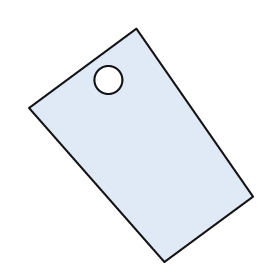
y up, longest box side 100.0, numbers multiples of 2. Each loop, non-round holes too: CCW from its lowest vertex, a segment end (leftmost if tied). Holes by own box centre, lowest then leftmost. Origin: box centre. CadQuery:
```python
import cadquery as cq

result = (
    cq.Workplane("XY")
    .moveTo(10.0, -50.0)
    .lineTo(48.0, -22.0)
    .lineTo(-2.0, 50.0)
    .lineTo(-48.0, 16.0)
    .close()
    .moveTo(-14.0, 28.0)
    .circle(6.0)
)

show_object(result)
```